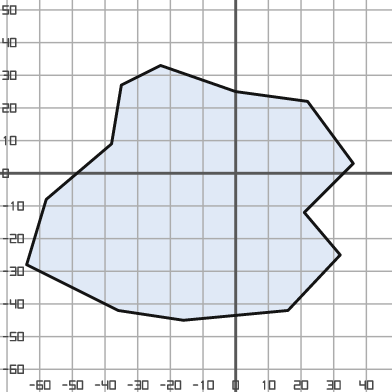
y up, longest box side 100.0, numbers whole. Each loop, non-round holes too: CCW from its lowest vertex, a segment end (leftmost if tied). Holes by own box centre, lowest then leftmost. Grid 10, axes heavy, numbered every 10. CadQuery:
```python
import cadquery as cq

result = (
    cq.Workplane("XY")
    .moveTo(-16.0, -45.0)
    .lineTo(16.0, -42.0)
    .lineTo(32.0, -25.0)
    .lineTo(21.0, -12.0)
    .lineTo(36.0, 3.0)
    .lineTo(22.0, 22.0)
    .lineTo(0.0, 25.0)
    .lineTo(-23.0, 33.0)
    .lineTo(-35.0, 27.0)
    .lineTo(-38.0, 9.0)
    .lineTo(-58.0, -8.0)
    .lineTo(-64.0, -28.0)
    .lineTo(-36.0, -42.0)
    .close()
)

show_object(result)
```